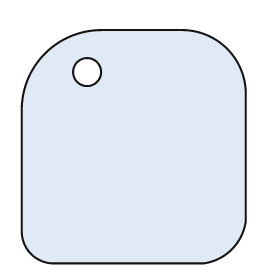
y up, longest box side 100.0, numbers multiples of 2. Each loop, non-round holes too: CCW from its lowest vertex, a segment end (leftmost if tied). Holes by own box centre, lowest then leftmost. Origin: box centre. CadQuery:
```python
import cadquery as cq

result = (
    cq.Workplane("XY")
    .moveTo(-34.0, -50.0)
    .lineTo(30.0, -50.0)
    .threePointArc((42.0, -44.0), (48.0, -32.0))
    .lineTo(48.0, 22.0)
    .threePointArc((40.0, 42.0), (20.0, 50.0))
    .lineTo(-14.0, 50.0)
    .threePointArc((-38.0, 40.0), (-48.0, 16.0))
    .lineTo(-48.0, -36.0)
    .threePointArc((-44.0, -46.0), (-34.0, -50.0))
    .close()
    .moveTo(-20.0, 32.0)
    .circle(6.0)
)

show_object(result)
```